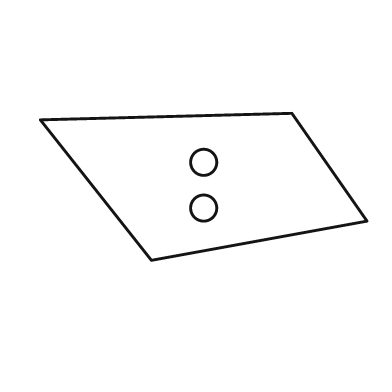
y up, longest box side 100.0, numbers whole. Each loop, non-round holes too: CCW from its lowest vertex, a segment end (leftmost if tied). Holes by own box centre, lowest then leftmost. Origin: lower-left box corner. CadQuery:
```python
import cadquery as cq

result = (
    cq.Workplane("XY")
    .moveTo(34.0, 0.0)
    .lineTo(100.0, 12.0)
    .lineTo(77.0, 45.0)
    .lineTo(0.0, 43.0)
    .close()
    .moveTo(50.0, 16.0)
    .circle(4.0)
    .moveTo(50.0, 30.0)
    .circle(4.0)
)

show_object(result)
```